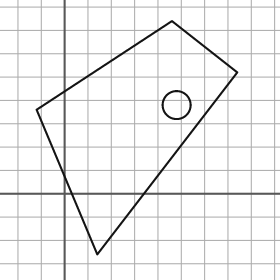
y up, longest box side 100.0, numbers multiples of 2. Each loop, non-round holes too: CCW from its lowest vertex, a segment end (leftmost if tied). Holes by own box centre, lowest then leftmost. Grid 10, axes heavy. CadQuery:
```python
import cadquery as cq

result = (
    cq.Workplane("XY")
    .moveTo(14.0, -26.0)
    .lineTo(74.0, 52.0)
    .lineTo(46.0, 74.0)
    .lineTo(-12.0, 36.0)
    .close()
    .moveTo(48.0, 38.0)
    .circle(6.0)
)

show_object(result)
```